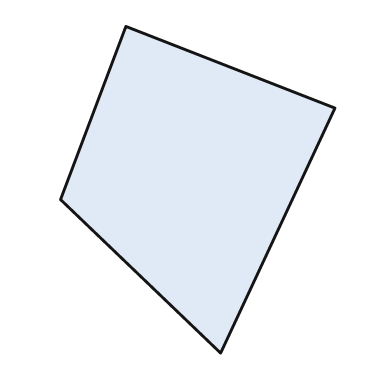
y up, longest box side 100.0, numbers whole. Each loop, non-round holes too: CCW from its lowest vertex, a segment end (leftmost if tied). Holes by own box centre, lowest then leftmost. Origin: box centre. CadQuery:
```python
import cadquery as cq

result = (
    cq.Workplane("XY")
    .moveTo(7.0, -50.0)
    .lineTo(42.0, 25.0)
    .lineTo(-22.0, 50.0)
    .lineTo(-42.0, -3.0)
    .close()
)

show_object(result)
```